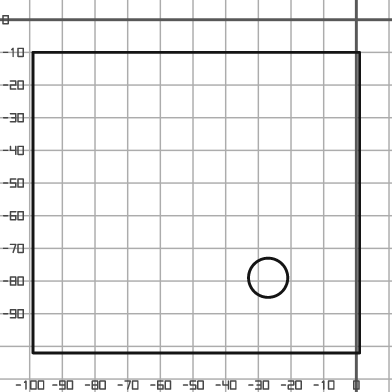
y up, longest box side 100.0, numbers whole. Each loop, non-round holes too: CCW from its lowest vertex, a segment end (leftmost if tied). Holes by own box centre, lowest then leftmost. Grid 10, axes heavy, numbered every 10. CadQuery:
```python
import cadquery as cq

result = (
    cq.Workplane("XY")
    .moveTo(-99.0, -102.0)
    .lineTo(1.0, -102.0)
    .lineTo(1.0, -10.0)
    .lineTo(-99.0, -10.0)
    .close()
    .moveTo(-27.0, -79.0)
    .circle(6.0)
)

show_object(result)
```